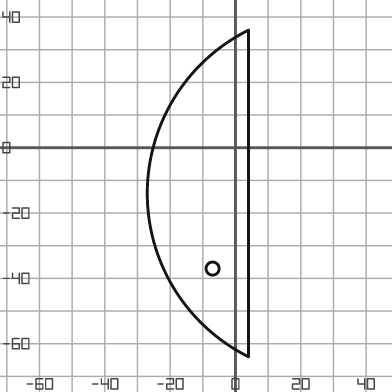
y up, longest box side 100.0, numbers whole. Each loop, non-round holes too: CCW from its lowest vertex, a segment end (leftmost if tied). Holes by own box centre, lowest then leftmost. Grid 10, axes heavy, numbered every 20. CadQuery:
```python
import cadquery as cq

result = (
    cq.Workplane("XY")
    .moveTo(4.0, -64.0)
    .lineTo(4.0, 36.0)
    .threePointArc((-27.0, -14.0), (4.0, -64.0))
    .close()
    .moveTo(-7.0, -37.0)
    .circle(2.0)
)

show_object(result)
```